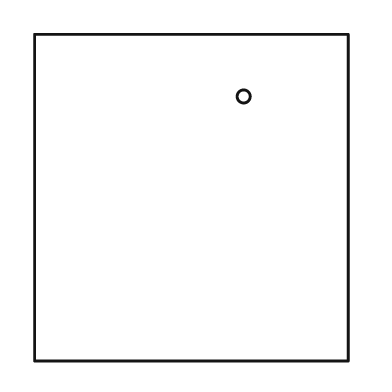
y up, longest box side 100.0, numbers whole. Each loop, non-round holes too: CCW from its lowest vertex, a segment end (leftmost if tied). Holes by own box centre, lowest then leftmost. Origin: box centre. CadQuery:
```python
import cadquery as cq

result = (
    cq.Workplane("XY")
    .moveTo(-48.0, -50.0)
    .lineTo(48.0, -50.0)
    .lineTo(48.0, 50.0)
    .lineTo(-48.0, 50.0)
    .close()
    .moveTo(16.0, 31.0)
    .circle(2.0)
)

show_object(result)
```